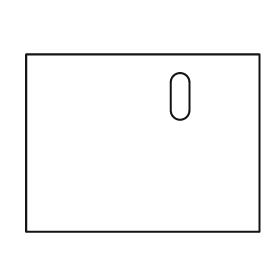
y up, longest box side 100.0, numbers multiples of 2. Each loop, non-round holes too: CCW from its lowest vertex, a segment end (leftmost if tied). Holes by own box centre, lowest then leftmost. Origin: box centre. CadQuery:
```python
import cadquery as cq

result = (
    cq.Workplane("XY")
    .moveTo(-50.0, -38.0)
    .lineTo(50.0, -38.0)
    .lineTo(50.0, 38.0)
    .lineTo(-50.0, 38.0)
    .close()
    .moveTo(12.0, 14.0)
    .threePointArc((16.0, 10.0), (20.0, 14.0))
    .lineTo(20.0, 26.0)
    .threePointArc((16.0, 30.0), (12.0, 26.0))
    .close()
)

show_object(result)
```